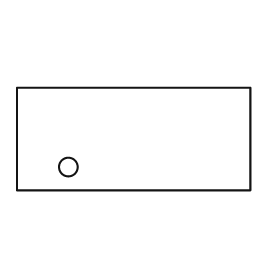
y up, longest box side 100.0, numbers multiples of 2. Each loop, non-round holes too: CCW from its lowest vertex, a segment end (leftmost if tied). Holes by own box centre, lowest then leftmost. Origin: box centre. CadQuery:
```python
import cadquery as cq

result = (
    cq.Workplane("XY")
    .moveTo(-50.0, -22.0)
    .lineTo(50.0, -22.0)
    .lineTo(50.0, 22.0)
    .lineTo(-50.0, 22.0)
    .close()
    .moveTo(-28.0, -12.0)
    .circle(4.0)
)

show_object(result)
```